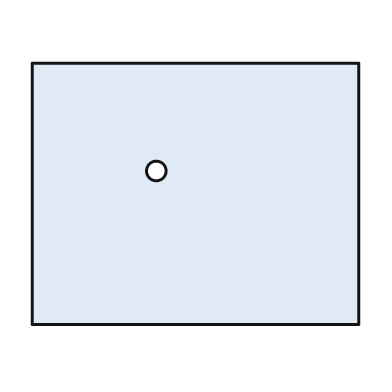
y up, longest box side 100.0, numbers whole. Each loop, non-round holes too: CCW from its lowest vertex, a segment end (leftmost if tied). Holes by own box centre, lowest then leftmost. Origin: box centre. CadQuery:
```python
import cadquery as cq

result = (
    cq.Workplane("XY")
    .moveTo(-50.0, -40.0)
    .lineTo(50.0, -40.0)
    .lineTo(50.0, 40.0)
    .lineTo(-50.0, 40.0)
    .close()
    .moveTo(-12.0, 7.0)
    .circle(3.0)
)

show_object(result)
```